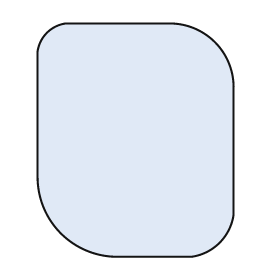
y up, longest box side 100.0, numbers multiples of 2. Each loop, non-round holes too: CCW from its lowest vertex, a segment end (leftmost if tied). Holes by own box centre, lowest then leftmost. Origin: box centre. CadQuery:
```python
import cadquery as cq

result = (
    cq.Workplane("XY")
    .moveTo(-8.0, -50.0)
    .lineTo(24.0, -50.0)
    .threePointArc((36.0, -44.0), (42.0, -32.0))
    .lineTo(42.0, 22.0)
    .threePointArc((34.0, 42.0), (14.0, 50.0))
    .lineTo(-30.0, 50.0)
    .threePointArc((-38.0, 46.0), (-42.0, 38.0))
    .lineTo(-42.0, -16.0)
    .threePointArc((-32.0, -40.0), (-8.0, -50.0))
    .close()
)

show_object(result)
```